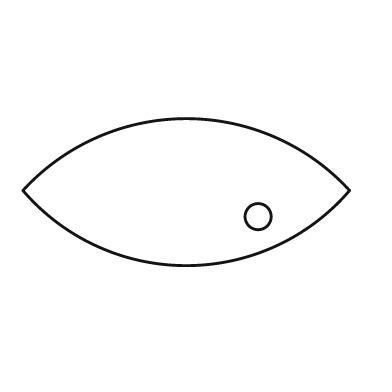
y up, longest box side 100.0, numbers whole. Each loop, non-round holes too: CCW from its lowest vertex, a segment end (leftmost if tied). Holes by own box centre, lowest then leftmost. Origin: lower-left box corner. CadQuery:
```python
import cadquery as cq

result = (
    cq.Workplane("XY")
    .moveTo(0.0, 23.0)
    .threePointArc((50.0, 0.0), (100.0, 23.0))
    .threePointArc((50.0, 45.0), (0.0, 23.0))
    .close()
    .moveTo(72.0, 15.0)
    .circle(4.0)
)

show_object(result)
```